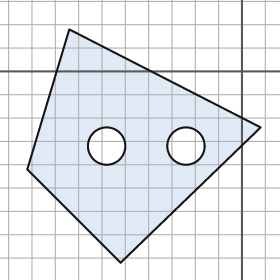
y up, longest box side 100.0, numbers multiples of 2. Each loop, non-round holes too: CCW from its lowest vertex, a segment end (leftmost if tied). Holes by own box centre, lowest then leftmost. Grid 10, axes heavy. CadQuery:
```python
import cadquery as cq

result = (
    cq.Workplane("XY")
    .moveTo(-52.0, -82.0)
    .lineTo(8.0, -24.0)
    .lineTo(-74.0, 18.0)
    .lineTo(-92.0, -42.0)
    .close()
    .moveTo(-58.0, -32.0)
    .circle(8.0)
    .moveTo(-24.0, -32.0)
    .circle(8.0)
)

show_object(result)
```